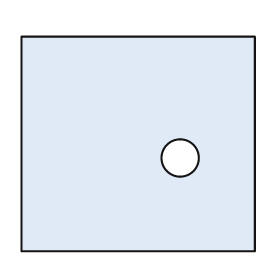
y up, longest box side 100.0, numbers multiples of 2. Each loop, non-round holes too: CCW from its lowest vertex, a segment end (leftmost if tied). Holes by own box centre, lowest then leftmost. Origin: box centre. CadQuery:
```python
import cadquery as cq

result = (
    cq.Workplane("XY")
    .moveTo(-50.0, -46.0)
    .lineTo(50.0, -46.0)
    .lineTo(50.0, 46.0)
    .lineTo(-50.0, 46.0)
    .close()
    .moveTo(18.0, -6.0)
    .circle(8.0)
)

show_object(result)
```